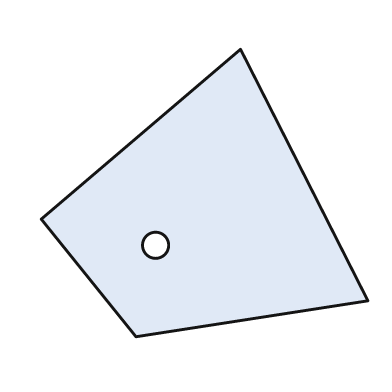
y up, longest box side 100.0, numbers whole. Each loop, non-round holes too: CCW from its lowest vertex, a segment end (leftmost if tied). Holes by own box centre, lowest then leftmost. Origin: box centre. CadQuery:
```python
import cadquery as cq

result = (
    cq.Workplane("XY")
    .moveTo(-21.0, -44.0)
    .lineTo(50.0, -33.0)
    .lineTo(11.0, 44.0)
    .lineTo(-50.0, -8.0)
    .close()
    .moveTo(-15.0, -16.0)
    .circle(4.0)
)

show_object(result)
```